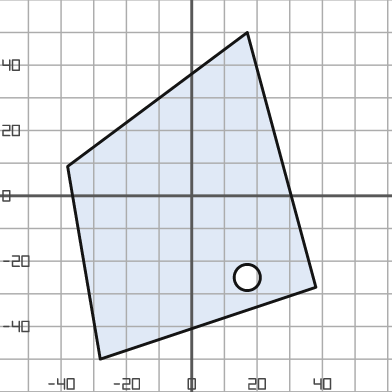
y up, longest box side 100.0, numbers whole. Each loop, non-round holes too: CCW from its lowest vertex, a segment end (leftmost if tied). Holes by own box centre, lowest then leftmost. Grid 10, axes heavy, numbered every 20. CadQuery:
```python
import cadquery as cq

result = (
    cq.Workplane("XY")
    .moveTo(-28.0, -50.0)
    .lineTo(38.0, -28.0)
    .lineTo(17.0, 50.0)
    .lineTo(-38.0, 9.0)
    .close()
    .moveTo(17.0, -25.0)
    .circle(4.0)
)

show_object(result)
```